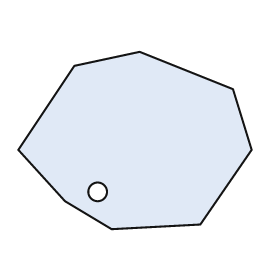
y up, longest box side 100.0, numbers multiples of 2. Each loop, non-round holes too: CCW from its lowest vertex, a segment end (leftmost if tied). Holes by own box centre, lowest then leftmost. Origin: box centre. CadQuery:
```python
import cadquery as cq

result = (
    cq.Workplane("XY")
    .moveTo(-10.0, -38.0)
    .lineTo(28.0, -36.0)
    .lineTo(50.0, -4.0)
    .lineTo(42.0, 22.0)
    .lineTo(2.0, 38.0)
    .lineTo(-26.0, 32.0)
    .lineTo(-50.0, -4.0)
    .lineTo(-30.0, -26.0)
    .close()
    .moveTo(-16.0, -22.0)
    .circle(4.0)
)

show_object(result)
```